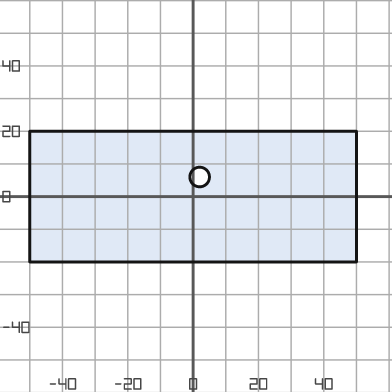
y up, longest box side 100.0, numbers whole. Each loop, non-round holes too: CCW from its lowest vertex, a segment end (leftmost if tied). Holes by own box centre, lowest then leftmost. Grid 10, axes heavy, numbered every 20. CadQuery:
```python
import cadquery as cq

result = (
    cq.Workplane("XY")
    .moveTo(-50.0, -20.0)
    .lineTo(50.0, -20.0)
    .lineTo(50.0, 20.0)
    .lineTo(-50.0, 20.0)
    .close()
    .moveTo(2.0, 6.0)
    .circle(3.0)
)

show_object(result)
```